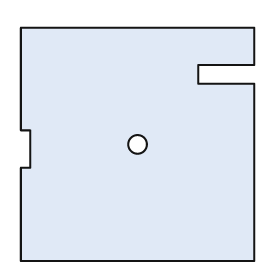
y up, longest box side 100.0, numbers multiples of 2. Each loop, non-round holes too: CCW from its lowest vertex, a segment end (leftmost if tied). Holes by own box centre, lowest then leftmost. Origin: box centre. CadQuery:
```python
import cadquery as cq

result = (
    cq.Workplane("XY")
    .moveTo(-50.0, -50.0)
    .lineTo(50.0, -50.0)
    .lineTo(50.0, 26.0)
    .lineTo(26.0, 26.0)
    .lineTo(26.0, 34.0)
    .lineTo(50.0, 34.0)
    .lineTo(50.0, 50.0)
    .lineTo(-50.0, 50.0)
    .lineTo(-50.0, 6.0)
    .lineTo(-46.0, 6.0)
    .lineTo(-46.0, -10.0)
    .lineTo(-50.0, -10.0)
    .close()
    .moveTo(0.0, 0.0)
    .circle(4.0)
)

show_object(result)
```